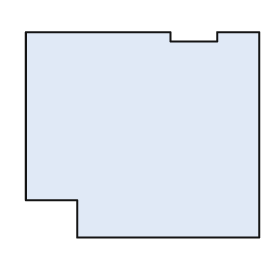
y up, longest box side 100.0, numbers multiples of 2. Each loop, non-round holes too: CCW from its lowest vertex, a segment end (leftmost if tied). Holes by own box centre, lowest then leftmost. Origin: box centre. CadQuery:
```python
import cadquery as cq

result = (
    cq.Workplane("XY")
    .moveTo(-28.0, -44.0)
    .lineTo(50.0, -44.0)
    .lineTo(50.0, 44.0)
    .lineTo(32.0, 44.0)
    .lineTo(32.0, 40.0)
    .lineTo(12.0, 40.0)
    .lineTo(12.0, 44.0)
    .lineTo(-50.0, 44.0)
    .lineTo(-50.0, -28.0)
    .lineTo(-28.0, -28.0)
    .close()
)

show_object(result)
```